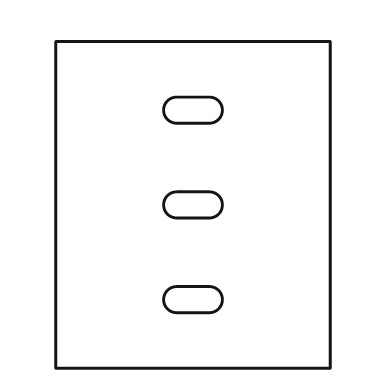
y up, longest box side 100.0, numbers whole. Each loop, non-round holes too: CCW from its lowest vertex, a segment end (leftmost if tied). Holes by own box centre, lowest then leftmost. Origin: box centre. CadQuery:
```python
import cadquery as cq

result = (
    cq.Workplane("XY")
    .moveTo(-42.0, -50.0)
    .lineTo(42.0, -50.0)
    .lineTo(42.0, 50.0)
    .lineTo(-42.0, 50.0)
    .close()
    .moveTo(-5.0, -33.0)
    .lineTo(5.0, -33.0)
    .threePointArc((9.0, -29.0), (5.0, -25.0))
    .lineTo(-5.0, -25.0)
    .threePointArc((-9.0, -29.0), (-5.0, -33.0))
    .close()
    .moveTo(-5.0, -4.0)
    .lineTo(5.0, -4.0)
    .threePointArc((9.0, 0.0), (5.0, 4.0))
    .lineTo(-5.0, 4.0)
    .threePointArc((-9.0, 0.0), (-5.0, -4.0))
    .close()
    .moveTo(-5.0, 25.0)
    .lineTo(5.0, 25.0)
    .threePointArc((9.0, 29.0), (5.0, 33.0))
    .lineTo(-5.0, 33.0)
    .threePointArc((-9.0, 29.0), (-5.0, 25.0))
    .close()
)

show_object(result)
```